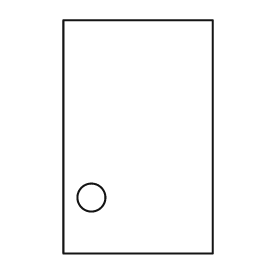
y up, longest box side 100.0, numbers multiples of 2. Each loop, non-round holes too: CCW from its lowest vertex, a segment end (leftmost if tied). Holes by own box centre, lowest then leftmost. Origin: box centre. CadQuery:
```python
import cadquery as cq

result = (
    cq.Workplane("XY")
    .moveTo(-32.0, -50.0)
    .lineTo(32.0, -50.0)
    .lineTo(32.0, 50.0)
    .lineTo(-32.0, 50.0)
    .close()
    .moveTo(-20.0, -26.0)
    .circle(6.0)
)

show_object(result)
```